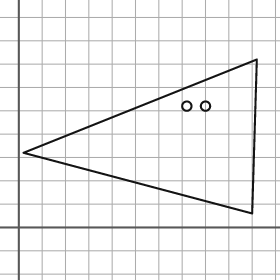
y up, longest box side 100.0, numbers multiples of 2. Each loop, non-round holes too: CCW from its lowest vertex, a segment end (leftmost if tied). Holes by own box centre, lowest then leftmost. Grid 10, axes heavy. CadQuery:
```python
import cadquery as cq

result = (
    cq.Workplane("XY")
    .moveTo(100.0, 6.0)
    .lineTo(102.0, 72.0)
    .lineTo(2.0, 32.0)
    .close()
    .moveTo(72.0, 52.0)
    .circle(2.0)
    .moveTo(80.0, 52.0)
    .circle(2.0)
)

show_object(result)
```